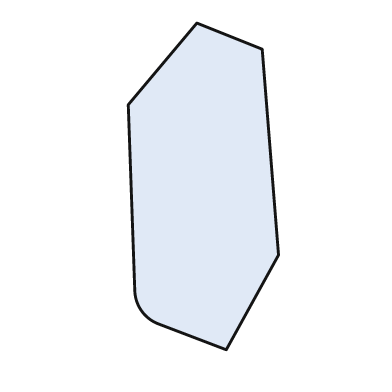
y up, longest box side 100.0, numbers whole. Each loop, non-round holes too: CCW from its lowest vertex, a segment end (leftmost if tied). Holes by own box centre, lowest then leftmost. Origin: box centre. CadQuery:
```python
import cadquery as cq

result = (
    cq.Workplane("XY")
    .moveTo(7.0, -50.0)
    .lineTo(23.0, -21.0)
    .lineTo(18.0, 42.0)
    .lineTo(-2.0, 50.0)
    .lineTo(-23.0, 25.0)
    .lineTo(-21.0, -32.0)
    .threePointArc((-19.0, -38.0), (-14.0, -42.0))
    .close()
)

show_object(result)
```